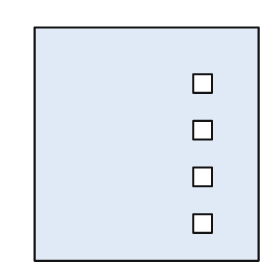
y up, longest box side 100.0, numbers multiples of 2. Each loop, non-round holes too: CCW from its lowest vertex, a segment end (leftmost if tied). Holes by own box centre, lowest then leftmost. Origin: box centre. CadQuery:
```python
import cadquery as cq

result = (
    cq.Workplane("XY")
    .moveTo(-48.0, -50.0)
    .lineTo(48.0, -50.0)
    .lineTo(48.0, 50.0)
    .lineTo(-48.0, 50.0)
    .close()
    .moveTo(20.0, -38.0)
    .lineTo(28.0, -38.0)
    .lineTo(28.0, -30.0)
    .lineTo(20.0, -30.0)
    .close()
    .moveTo(20.0, -18.0)
    .lineTo(28.0, -18.0)
    .lineTo(28.0, -10.0)
    .lineTo(20.0, -10.0)
    .close()
    .moveTo(20.0, 2.0)
    .lineTo(28.0, 2.0)
    .lineTo(28.0, 10.0)
    .lineTo(20.0, 10.0)
    .close()
    .moveTo(20.0, 22.0)
    .lineTo(28.0, 22.0)
    .lineTo(28.0, 30.0)
    .lineTo(20.0, 30.0)
    .close()
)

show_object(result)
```